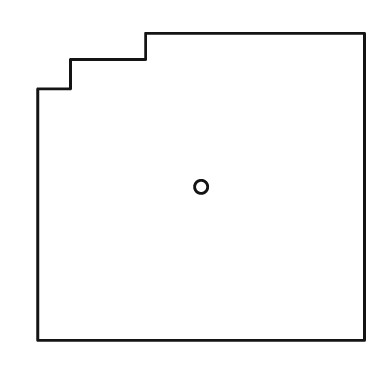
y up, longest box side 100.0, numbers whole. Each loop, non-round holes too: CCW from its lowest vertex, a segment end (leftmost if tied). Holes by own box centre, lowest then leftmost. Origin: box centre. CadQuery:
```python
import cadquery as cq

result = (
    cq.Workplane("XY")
    .moveTo(-50.0, -47.0)
    .lineTo(50.0, -47.0)
    .lineTo(50.0, 47.0)
    .lineTo(-17.0, 47.0)
    .lineTo(-17.0, 39.0)
    .lineTo(-40.0, 39.0)
    .lineTo(-40.0, 30.0)
    .lineTo(-50.0, 30.0)
    .close()
    .moveTo(0.0, 0.0)
    .circle(2.0)
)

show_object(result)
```